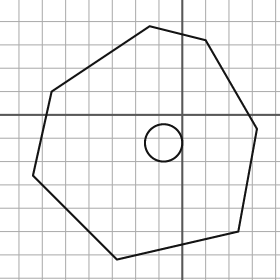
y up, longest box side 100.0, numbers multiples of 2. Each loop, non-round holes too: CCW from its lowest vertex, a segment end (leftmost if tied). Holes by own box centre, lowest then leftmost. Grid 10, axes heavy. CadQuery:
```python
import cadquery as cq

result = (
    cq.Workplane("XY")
    .moveTo(-28.0, -62.0)
    .lineTo(24.0, -50.0)
    .lineTo(32.0, -6.0)
    .lineTo(10.0, 32.0)
    .lineTo(-14.0, 38.0)
    .lineTo(-56.0, 10.0)
    .lineTo(-64.0, -26.0)
    .close()
    .moveTo(-8.0, -12.0)
    .circle(8.0)
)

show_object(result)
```